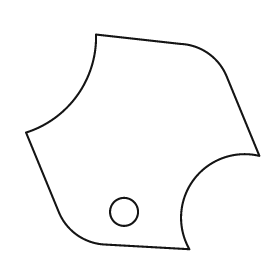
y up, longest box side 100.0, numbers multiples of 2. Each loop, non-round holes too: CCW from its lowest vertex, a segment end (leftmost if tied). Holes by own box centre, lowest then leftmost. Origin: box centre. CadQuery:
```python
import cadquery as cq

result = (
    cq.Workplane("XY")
    .moveTo(20.0, -46.0)
    .threePointArc((22.0, -16.0), (50.0, -6.0))
    .lineTo(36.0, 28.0)
    .threePointArc((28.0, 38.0), (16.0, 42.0))
    .lineTo(-20.0, 46.0)
    .threePointArc((-28.0, 20.0), (-50.0, 4.0))
    .lineTo(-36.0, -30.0)
    .threePointArc((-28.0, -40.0), (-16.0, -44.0))
    .close()
    .moveTo(-8.0, -30.0)
    .circle(6.0)
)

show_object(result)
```